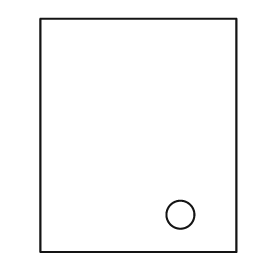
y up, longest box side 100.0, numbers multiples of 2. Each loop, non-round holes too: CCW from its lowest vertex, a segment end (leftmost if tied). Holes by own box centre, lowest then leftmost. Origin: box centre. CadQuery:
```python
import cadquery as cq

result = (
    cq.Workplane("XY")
    .moveTo(-42.0, -50.0)
    .lineTo(42.0, -50.0)
    .lineTo(42.0, 50.0)
    .lineTo(-42.0, 50.0)
    .close()
    .moveTo(18.0, -34.0)
    .circle(6.0)
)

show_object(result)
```